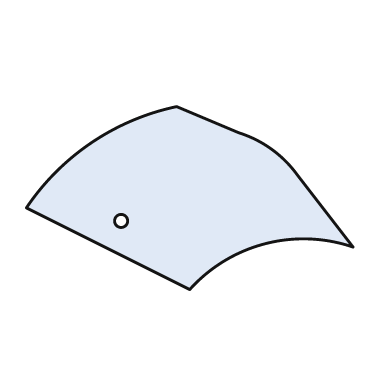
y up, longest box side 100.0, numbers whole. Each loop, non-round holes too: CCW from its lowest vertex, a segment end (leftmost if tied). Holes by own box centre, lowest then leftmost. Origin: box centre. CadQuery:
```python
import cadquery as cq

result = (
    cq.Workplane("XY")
    .moveTo(0.0, -28.0)
    .threePointArc((23.0, -14.0), (50.0, -15.0))
    .lineTo(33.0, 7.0)
    .threePointArc((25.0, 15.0), (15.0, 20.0))
    .lineTo(-4.0, 28.0)
    .threePointArc((-30.0, 17.0), (-50.0, -3.0))
    .close()
    .moveTo(-21.0, -7.0)
    .circle(2.0)
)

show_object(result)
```